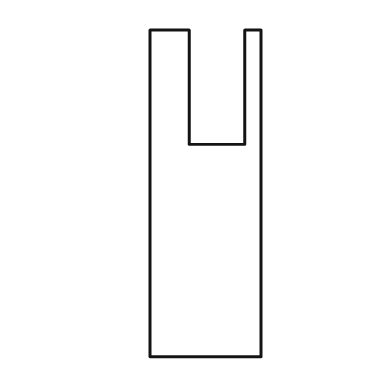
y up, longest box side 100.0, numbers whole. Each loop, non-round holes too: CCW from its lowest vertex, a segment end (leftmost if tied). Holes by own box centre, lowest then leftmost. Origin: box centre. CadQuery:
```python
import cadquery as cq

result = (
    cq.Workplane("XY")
    .moveTo(-17.0, -50.0)
    .lineTo(17.0, -50.0)
    .lineTo(17.0, 50.0)
    .lineTo(12.0, 50.0)
    .lineTo(12.0, 15.0)
    .lineTo(-5.0, 15.0)
    .lineTo(-5.0, 50.0)
    .lineTo(-17.0, 50.0)
    .close()
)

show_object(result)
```